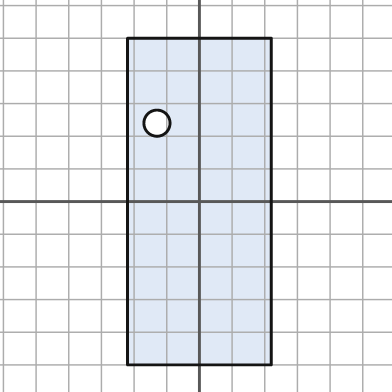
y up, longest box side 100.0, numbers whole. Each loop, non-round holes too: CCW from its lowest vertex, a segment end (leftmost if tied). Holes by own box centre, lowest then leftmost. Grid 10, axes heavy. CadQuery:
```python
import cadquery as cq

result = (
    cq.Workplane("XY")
    .moveTo(-22.0, -50.0)
    .lineTo(22.0, -50.0)
    .lineTo(22.0, 50.0)
    .lineTo(-22.0, 50.0)
    .close()
    .moveTo(-13.0, 24.0)
    .circle(4.0)
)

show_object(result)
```